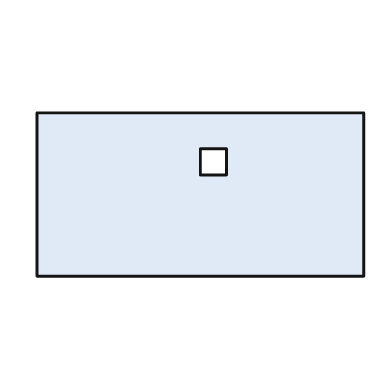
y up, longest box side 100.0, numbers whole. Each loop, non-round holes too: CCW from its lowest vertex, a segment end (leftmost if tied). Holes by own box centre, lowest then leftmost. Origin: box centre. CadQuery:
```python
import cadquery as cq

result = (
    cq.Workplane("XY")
    .moveTo(-50.0, -25.0)
    .lineTo(50.0, -25.0)
    .lineTo(50.0, 25.0)
    .lineTo(-50.0, 25.0)
    .close()
    .moveTo(0.0, 6.0)
    .lineTo(8.0, 6.0)
    .lineTo(8.0, 14.0)
    .lineTo(0.0, 14.0)
    .close()
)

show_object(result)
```